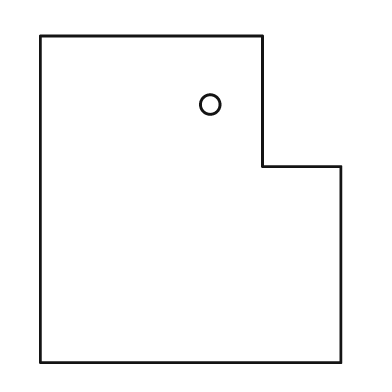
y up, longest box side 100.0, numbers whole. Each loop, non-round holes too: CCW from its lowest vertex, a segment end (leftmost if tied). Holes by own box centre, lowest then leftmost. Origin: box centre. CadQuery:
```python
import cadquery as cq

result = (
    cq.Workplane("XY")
    .moveTo(-46.0, -50.0)
    .lineTo(46.0, -50.0)
    .lineTo(46.0, 10.0)
    .lineTo(22.0, 10.0)
    .lineTo(22.0, 50.0)
    .lineTo(-46.0, 50.0)
    .close()
    .moveTo(6.0, 29.0)
    .circle(3.0)
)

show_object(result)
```